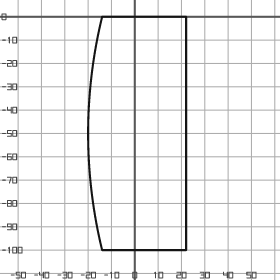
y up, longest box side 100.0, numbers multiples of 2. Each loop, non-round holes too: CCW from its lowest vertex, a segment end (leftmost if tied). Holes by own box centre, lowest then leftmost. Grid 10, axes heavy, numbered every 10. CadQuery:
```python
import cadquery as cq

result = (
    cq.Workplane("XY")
    .moveTo(-14.0, -100.0)
    .lineTo(22.0, -100.0)
    .lineTo(22.0, 0.0)
    .lineTo(-14.0, 0.0)
    .threePointArc((-20.0, -50.0), (-14.0, -100.0))
    .close()
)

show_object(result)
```